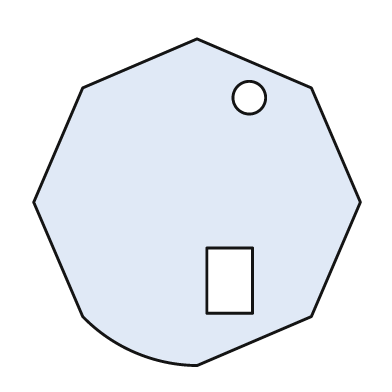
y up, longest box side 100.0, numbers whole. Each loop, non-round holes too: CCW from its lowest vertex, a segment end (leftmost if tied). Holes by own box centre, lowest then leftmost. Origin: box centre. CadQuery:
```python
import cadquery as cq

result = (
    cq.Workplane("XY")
    .moveTo(0.0, -50.0)
    .lineTo(35.0, -35.0)
    .lineTo(50.0, 0.0)
    .lineTo(35.0, 35.0)
    .lineTo(0.0, 50.0)
    .lineTo(-35.0, 35.0)
    .lineTo(-50.0, 0.0)
    .lineTo(-35.0, -35.0)
    .threePointArc((-19.0, -46.0), (0.0, -50.0))
    .close()
    .moveTo(3.0, -34.0)
    .lineTo(17.0, -34.0)
    .lineTo(17.0, -14.0)
    .lineTo(3.0, -14.0)
    .close()
    .moveTo(16.0, 32.0)
    .circle(5.0)
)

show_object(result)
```